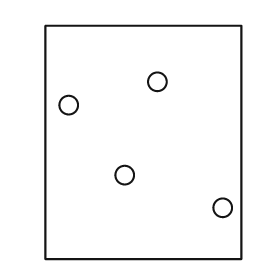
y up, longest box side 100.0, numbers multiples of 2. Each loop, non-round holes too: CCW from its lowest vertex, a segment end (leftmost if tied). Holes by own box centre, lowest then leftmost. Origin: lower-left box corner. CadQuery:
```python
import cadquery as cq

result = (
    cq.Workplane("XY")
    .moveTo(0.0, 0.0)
    .lineTo(84.0, 0.0)
    .lineTo(84.0, 100.0)
    .lineTo(0.0, 100.0)
    .close()
    .moveTo(76.0, 22.0)
    .circle(4.0)
    .moveTo(34.0, 36.0)
    .circle(4.0)
    .moveTo(10.0, 66.0)
    .circle(4.0)
    .moveTo(48.0, 76.0)
    .circle(4.0)
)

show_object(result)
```